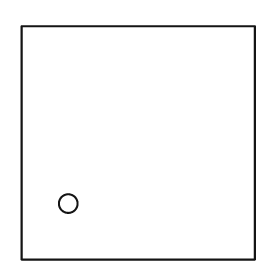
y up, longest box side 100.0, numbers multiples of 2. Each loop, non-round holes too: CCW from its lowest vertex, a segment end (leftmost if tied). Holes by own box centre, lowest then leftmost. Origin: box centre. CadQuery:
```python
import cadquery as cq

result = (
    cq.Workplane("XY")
    .moveTo(-50.0, -50.0)
    .lineTo(50.0, -50.0)
    .lineTo(50.0, 50.0)
    .lineTo(-50.0, 50.0)
    .close()
    .moveTo(-30.0, -26.0)
    .circle(4.0)
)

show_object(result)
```